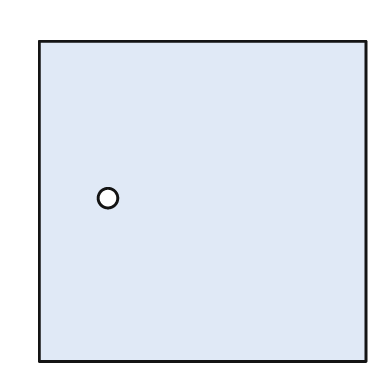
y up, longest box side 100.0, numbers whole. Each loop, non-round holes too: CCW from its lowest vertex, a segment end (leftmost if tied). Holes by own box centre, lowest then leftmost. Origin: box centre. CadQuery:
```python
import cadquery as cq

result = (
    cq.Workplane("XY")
    .moveTo(-50.0, -49.0)
    .lineTo(50.0, -49.0)
    .lineTo(50.0, 49.0)
    .lineTo(-50.0, 49.0)
    .close()
    .moveTo(-29.0, 1.0)
    .circle(3.0)
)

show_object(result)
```